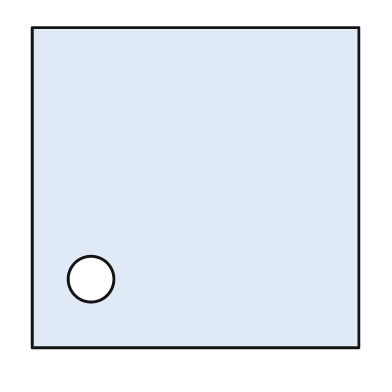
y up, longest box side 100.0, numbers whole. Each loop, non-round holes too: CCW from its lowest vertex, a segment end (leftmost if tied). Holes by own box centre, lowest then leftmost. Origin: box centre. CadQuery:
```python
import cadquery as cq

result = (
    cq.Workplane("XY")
    .moveTo(-50.0, -49.0)
    .lineTo(50.0, -49.0)
    .lineTo(50.0, 49.0)
    .lineTo(-50.0, 49.0)
    .close()
    .moveTo(-32.0, -28.0)
    .circle(7.0)
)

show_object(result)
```